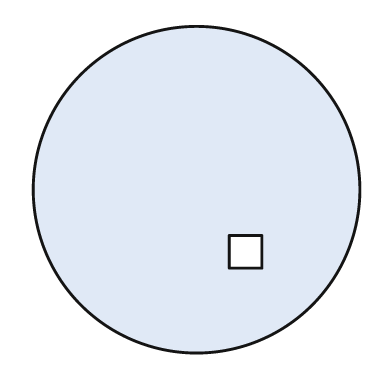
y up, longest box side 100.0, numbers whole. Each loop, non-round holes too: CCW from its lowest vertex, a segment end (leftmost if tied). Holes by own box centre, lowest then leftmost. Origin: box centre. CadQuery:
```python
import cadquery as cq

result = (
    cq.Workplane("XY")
    .moveTo(0.0, 0.0)
    .circle(50.0)
    .moveTo(10.0, -24.0)
    .lineTo(20.0, -24.0)
    .lineTo(20.0, -14.0)
    .lineTo(10.0, -14.0)
    .close()
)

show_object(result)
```